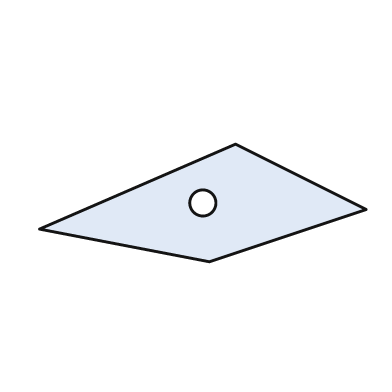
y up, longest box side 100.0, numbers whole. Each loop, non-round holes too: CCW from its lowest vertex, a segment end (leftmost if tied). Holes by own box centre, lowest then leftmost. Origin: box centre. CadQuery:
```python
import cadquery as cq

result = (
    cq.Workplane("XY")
    .moveTo(2.0, -18.0)
    .lineTo(50.0, -2.0)
    .lineTo(10.0, 18.0)
    .lineTo(-50.0, -8.0)
    .close()
    .moveTo(0.0, 0.0)
    .circle(4.0)
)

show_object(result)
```